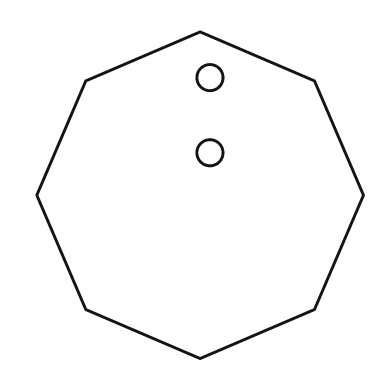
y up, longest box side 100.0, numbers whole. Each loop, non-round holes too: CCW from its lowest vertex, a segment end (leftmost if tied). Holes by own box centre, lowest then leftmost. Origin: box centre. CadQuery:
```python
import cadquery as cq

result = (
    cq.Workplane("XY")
    .moveTo(0.0, -50.0)
    .lineTo(35.0, -35.0)
    .lineTo(50.0, 0.0)
    .lineTo(35.0, 35.0)
    .lineTo(0.0, 50.0)
    .lineTo(-35.0, 35.0)
    .lineTo(-50.0, 0.0)
    .lineTo(-35.0, -35.0)
    .close()
    .moveTo(3.0, 13.0)
    .circle(4.0)
    .moveTo(3.0, 36.0)
    .circle(4.0)
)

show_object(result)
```